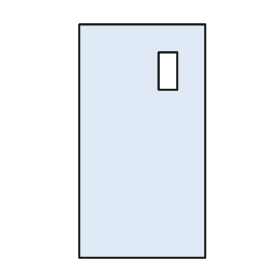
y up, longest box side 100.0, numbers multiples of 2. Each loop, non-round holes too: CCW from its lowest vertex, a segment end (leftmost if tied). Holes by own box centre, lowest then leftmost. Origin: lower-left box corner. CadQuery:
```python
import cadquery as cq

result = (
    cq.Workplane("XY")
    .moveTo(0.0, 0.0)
    .lineTo(54.0, 0.0)
    .lineTo(54.0, 100.0)
    .lineTo(0.0, 100.0)
    .close()
    .moveTo(34.0, 72.0)
    .lineTo(42.0, 72.0)
    .lineTo(42.0, 88.0)
    .lineTo(34.0, 88.0)
    .close()
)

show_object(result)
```